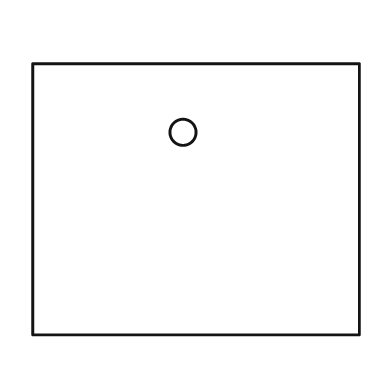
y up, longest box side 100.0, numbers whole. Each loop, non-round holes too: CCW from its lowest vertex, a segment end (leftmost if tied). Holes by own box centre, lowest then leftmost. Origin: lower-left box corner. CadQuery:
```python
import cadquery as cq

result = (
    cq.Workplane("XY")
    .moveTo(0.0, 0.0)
    .lineTo(100.0, 0.0)
    .lineTo(100.0, 83.0)
    .lineTo(0.0, 83.0)
    .close()
    .moveTo(46.0, 62.0)
    .circle(4.0)
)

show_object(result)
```